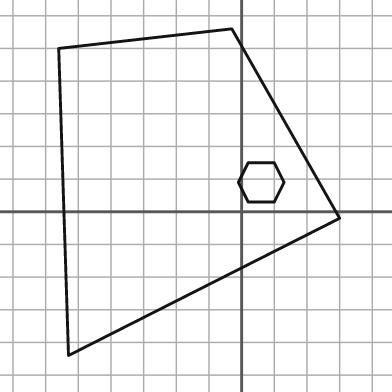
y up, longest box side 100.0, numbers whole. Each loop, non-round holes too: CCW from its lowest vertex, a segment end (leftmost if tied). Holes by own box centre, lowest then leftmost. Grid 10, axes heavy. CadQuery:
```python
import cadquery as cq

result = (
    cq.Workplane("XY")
    .moveTo(-53.0, -44.0)
    .lineTo(30.0, -2.0)
    .lineTo(-3.0, 56.0)
    .lineTo(-56.0, 50.0)
    .close()
    .moveTo(2.0, 3.0)
    .lineTo(10.0, 3.0)
    .lineTo(13.0, 9.0)
    .lineTo(10.0, 15.0)
    .lineTo(2.0, 15.0)
    .lineTo(-1.0, 9.0)
    .close()
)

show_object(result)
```